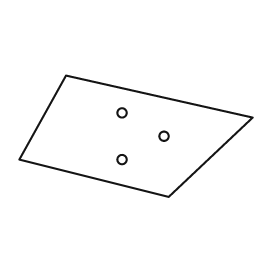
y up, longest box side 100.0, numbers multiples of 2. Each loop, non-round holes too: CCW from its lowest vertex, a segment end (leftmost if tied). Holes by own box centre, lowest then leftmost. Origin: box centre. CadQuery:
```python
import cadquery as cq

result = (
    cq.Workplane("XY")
    .moveTo(14.0, -26.0)
    .lineTo(50.0, 8.0)
    .lineTo(-30.0, 26.0)
    .lineTo(-50.0, -10.0)
    .close()
    .moveTo(-6.0, -10.0)
    .circle(2.0)
    .moveTo(12.0, 0.0)
    .circle(2.0)
    .moveTo(-6.0, 10.0)
    .circle(2.0)
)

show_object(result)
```